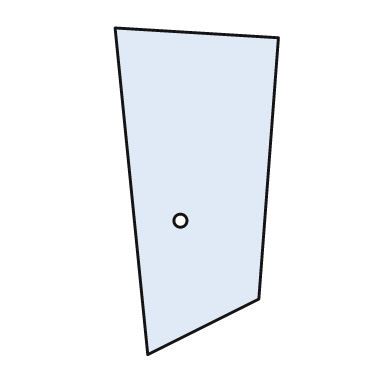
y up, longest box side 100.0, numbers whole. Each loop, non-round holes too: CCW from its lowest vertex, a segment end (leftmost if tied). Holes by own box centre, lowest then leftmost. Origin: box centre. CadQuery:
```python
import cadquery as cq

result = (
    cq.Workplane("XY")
    .moveTo(-15.0, -50.0)
    .lineTo(19.0, -33.0)
    .lineTo(25.0, 47.0)
    .lineTo(-25.0, 50.0)
    .close()
    .moveTo(-5.0, -9.0)
    .circle(2.0)
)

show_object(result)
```